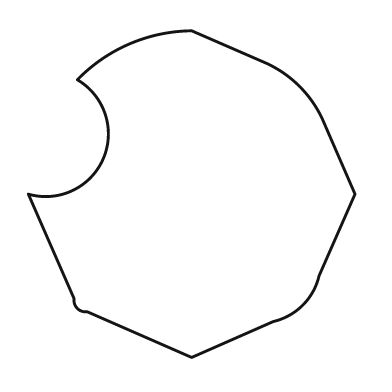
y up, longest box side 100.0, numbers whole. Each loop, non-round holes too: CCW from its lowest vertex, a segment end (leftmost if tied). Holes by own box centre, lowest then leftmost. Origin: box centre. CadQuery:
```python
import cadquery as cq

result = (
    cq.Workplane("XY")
    .moveTo(0.0, -50.0)
    .lineTo(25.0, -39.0)
    .threePointArc((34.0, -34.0), (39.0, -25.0))
    .lineTo(50.0, 0.0)
    .lineTo(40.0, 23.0)
    .threePointArc((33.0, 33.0), (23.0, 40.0))
    .lineTo(0.0, 50.0)
    .threePointArc((-19.0, 46.0), (-35.0, 35.0))
    .threePointArc((-27.0, 11.0), (-50.0, 0.0))
    .lineTo(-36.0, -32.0)
    .threePointArc((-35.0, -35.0), (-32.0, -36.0))
    .close()
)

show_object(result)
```